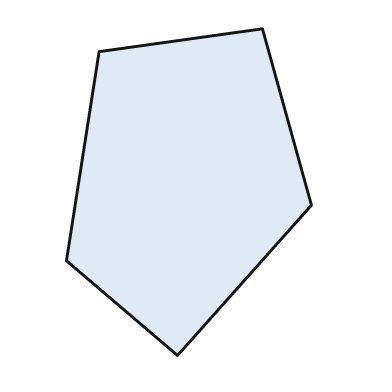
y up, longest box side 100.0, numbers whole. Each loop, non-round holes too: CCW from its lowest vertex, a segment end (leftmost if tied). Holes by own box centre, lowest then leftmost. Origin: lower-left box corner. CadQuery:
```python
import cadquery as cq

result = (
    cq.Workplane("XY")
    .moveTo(34.0, 0.0)
    .lineTo(75.0, 46.0)
    .lineTo(60.0, 100.0)
    .lineTo(10.0, 93.0)
    .lineTo(0.0, 29.0)
    .close()
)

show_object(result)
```